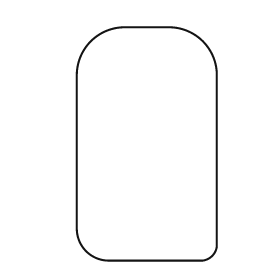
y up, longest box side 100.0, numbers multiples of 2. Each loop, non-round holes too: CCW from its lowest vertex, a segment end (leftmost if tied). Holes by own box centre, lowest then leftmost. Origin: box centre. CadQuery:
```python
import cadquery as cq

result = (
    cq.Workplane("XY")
    .moveTo(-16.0, -50.0)
    .lineTo(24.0, -50.0)
    .threePointArc((28.0, -48.0), (30.0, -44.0))
    .lineTo(30.0, 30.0)
    .threePointArc((24.0, 44.0), (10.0, 50.0))
    .lineTo(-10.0, 50.0)
    .threePointArc((-24.0, 44.0), (-30.0, 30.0))
    .lineTo(-30.0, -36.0)
    .threePointArc((-26.0, -46.0), (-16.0, -50.0))
    .close()
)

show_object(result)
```